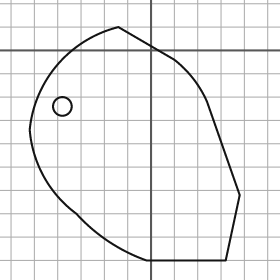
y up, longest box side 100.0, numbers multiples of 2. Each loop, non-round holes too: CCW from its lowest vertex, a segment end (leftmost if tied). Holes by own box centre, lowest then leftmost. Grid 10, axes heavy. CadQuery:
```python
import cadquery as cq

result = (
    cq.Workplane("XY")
    .moveTo(-2.0, -90.0)
    .lineTo(32.0, -90.0)
    .lineTo(38.0, -62.0)
    .lineTo(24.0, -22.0)
    .threePointArc((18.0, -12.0), (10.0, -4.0))
    .lineTo(-14.0, 10.0)
    .threePointArc((-40.0, -6.0), (-52.0, -34.0))
    .threePointArc((-46.0, -54.0), (-32.0, -70.0))
    .threePointArc((-18.0, -82.0), (-2.0, -90.0))
    .close()
    .moveTo(-38.0, -24.0)
    .circle(4.0)
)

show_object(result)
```